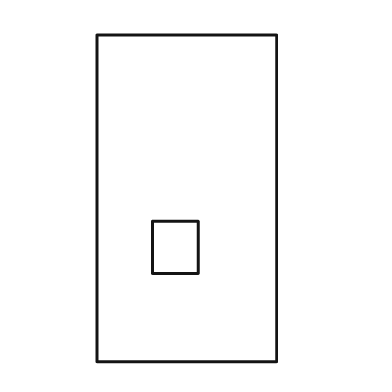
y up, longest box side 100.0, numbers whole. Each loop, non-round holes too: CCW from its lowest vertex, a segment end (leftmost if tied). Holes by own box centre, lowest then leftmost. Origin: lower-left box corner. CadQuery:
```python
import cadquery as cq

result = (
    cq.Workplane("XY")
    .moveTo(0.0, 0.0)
    .lineTo(55.0, 0.0)
    .lineTo(55.0, 100.0)
    .lineTo(0.0, 100.0)
    .close()
    .moveTo(17.0, 27.0)
    .lineTo(31.0, 27.0)
    .lineTo(31.0, 43.0)
    .lineTo(17.0, 43.0)
    .close()
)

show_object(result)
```